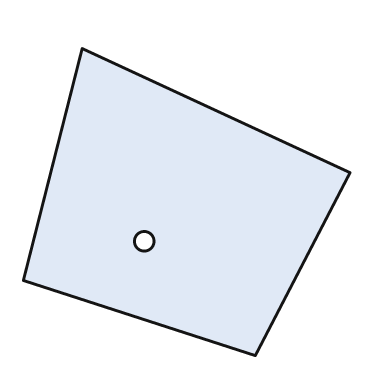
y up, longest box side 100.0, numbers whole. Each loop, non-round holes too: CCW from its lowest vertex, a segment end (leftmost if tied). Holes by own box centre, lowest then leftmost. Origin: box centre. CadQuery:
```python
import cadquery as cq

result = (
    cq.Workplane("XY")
    .moveTo(21.0, -47.0)
    .lineTo(50.0, 9.0)
    .lineTo(-32.0, 47.0)
    .lineTo(-50.0, -24.0)
    .close()
    .moveTo(-13.0, -12.0)
    .circle(3.0)
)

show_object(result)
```